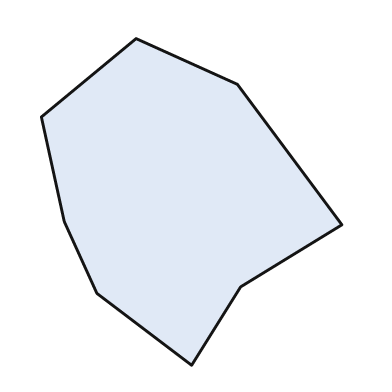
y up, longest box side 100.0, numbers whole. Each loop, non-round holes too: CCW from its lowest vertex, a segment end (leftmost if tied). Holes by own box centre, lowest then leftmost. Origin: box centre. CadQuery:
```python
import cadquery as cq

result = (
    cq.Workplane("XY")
    .moveTo(0.0, -50.0)
    .lineTo(15.0, -26.0)
    .lineTo(46.0, -7.0)
    .lineTo(14.0, 36.0)
    .lineTo(-17.0, 50.0)
    .lineTo(-46.0, 26.0)
    .lineTo(-39.0, -6.0)
    .lineTo(-29.0, -28.0)
    .close()
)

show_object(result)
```